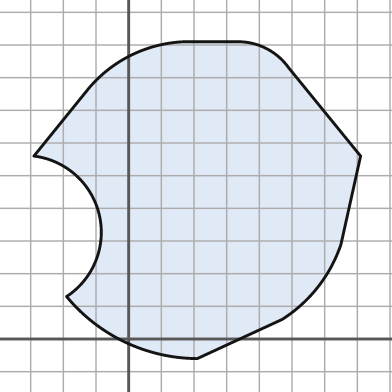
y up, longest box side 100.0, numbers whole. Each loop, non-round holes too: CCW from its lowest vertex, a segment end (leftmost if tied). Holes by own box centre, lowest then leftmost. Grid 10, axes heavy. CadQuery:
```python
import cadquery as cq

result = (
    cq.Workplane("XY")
    .moveTo(21.0, -6.0)
    .lineTo(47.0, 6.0)
    .threePointArc((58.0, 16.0), (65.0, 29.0))
    .lineTo(71.0, 56.0)
    .lineTo(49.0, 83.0)
    .threePointArc((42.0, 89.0), (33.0, 91.0))
    .lineTo(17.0, 91.0)
    .threePointArc((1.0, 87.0), (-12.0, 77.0))
    .lineTo(-29.0, 56.0)
    .threePointArc((-9.0, 38.0), (-19.0, 13.0))
    .threePointArc((-1.0, -1.0), (21.0, -6.0))
    .close()
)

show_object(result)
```